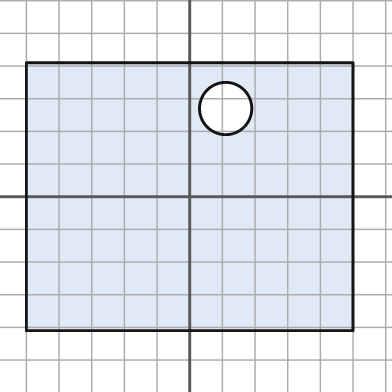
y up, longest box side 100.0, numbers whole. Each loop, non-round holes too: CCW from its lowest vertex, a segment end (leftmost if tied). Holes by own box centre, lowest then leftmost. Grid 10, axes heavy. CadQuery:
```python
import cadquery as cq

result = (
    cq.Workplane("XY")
    .moveTo(-50.0, -41.0)
    .lineTo(50.0, -41.0)
    .lineTo(50.0, 41.0)
    .lineTo(-50.0, 41.0)
    .close()
    .moveTo(11.0, 27.0)
    .circle(8.0)
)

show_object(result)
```